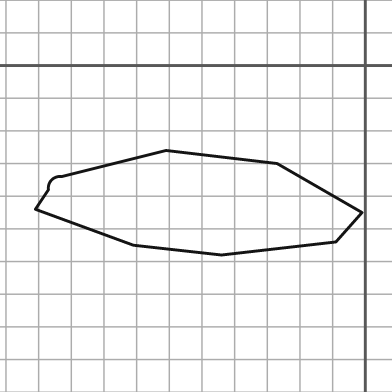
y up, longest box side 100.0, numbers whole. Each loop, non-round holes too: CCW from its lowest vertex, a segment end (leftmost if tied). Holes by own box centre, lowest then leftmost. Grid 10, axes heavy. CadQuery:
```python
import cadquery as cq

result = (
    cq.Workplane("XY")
    .moveTo(-44.0, -58.0)
    .lineTo(-9.0, -54.0)
    .lineTo(-1.0, -45.0)
    .lineTo(-27.0, -30.0)
    .lineTo(-61.0, -26.0)
    .lineTo(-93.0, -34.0)
    .threePointArc((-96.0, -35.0), (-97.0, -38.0))
    .lineTo(-101.0, -44.0)
    .lineTo(-71.0, -55.0)
    .close()
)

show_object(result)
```